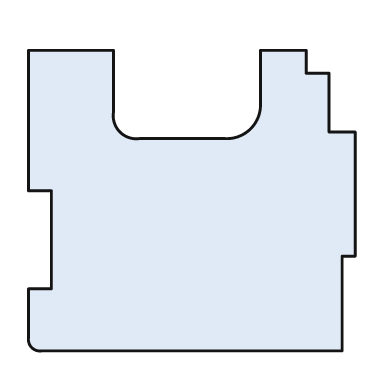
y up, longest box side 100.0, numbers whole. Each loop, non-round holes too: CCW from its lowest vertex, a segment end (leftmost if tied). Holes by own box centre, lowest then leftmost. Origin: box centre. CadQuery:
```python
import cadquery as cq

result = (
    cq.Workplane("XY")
    .moveTo(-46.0, -46.0)
    .lineTo(46.0, -46.0)
    .lineTo(46.0, -17.0)
    .lineTo(50.0, -17.0)
    .lineTo(50.0, 21.0)
    .lineTo(42.0, 21.0)
    .lineTo(42.0, 39.0)
    .lineTo(35.0, 39.0)
    .lineTo(35.0, 46.0)
    .lineTo(21.0, 46.0)
    .lineTo(21.0, 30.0)
    .threePointArc((18.0, 22.0), (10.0, 19.0))
    .lineTo(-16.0, 19.0)
    .threePointArc((-22.0, 21.0), (-24.0, 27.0))
    .lineTo(-24.0, 46.0)
    .lineTo(-50.0, 46.0)
    .lineTo(-50.0, 3.0)
    .lineTo(-43.0, 3.0)
    .lineTo(-43.0, -27.0)
    .lineTo(-50.0, -27.0)
    .lineTo(-50.0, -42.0)
    .threePointArc((-49.0, -45.0), (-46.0, -46.0))
    .close()
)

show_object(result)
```